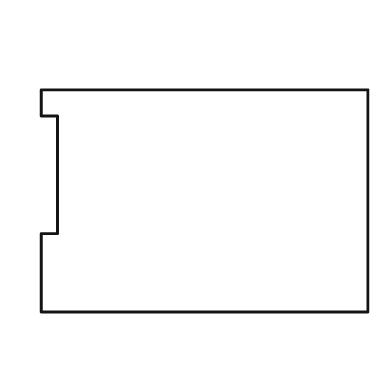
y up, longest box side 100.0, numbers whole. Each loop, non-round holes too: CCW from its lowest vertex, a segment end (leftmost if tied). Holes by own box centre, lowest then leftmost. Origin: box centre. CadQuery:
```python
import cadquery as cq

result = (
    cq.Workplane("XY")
    .moveTo(-50.0, -34.0)
    .lineTo(50.0, -34.0)
    .lineTo(50.0, 34.0)
    .lineTo(-50.0, 34.0)
    .lineTo(-50.0, 26.0)
    .lineTo(-45.0, 26.0)
    .lineTo(-45.0, -10.0)
    .lineTo(-50.0, -10.0)
    .close()
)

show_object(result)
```